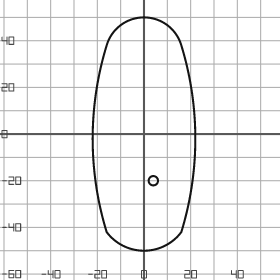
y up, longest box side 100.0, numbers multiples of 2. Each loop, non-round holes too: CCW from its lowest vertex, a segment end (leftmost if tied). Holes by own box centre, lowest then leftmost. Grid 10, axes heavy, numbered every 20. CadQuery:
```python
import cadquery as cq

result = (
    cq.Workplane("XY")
    .moveTo(-16.0, -42.0)
    .threePointArc((0.0, -50.0), (16.0, -42.0))
    .threePointArc((22.0, -2.0), (16.0, 38.0))
    .threePointArc((0.0, 50.0), (-16.0, 38.0))
    .threePointArc((-22.0, -2.0), (-16.0, -42.0))
    .close()
    .moveTo(4.0, -20.0)
    .circle(2.0)
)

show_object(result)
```